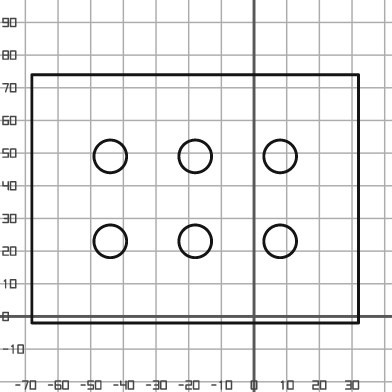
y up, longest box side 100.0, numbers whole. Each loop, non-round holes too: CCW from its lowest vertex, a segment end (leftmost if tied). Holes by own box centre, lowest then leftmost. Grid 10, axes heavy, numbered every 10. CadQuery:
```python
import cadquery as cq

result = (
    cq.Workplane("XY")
    .moveTo(-68.0, -2.0)
    .lineTo(32.0, -2.0)
    .lineTo(32.0, 74.0)
    .lineTo(-68.0, 74.0)
    .close()
    .moveTo(-44.0, 23.0)
    .circle(5.0)
    .moveTo(-18.0, 23.0)
    .circle(5.0)
    .moveTo(8.0, 23.0)
    .circle(5.0)
    .moveTo(-44.0, 49.0)
    .circle(5.0)
    .moveTo(-18.0, 49.0)
    .circle(5.0)
    .moveTo(8.0, 49.0)
    .circle(5.0)
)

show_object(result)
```